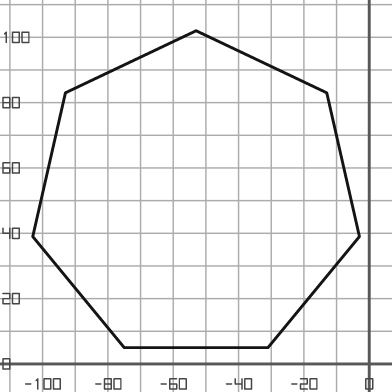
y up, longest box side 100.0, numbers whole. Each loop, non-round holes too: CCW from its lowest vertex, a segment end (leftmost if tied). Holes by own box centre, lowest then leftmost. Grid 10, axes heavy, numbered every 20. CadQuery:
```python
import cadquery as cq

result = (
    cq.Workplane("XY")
    .moveTo(-75.0, 5.0)
    .lineTo(-31.0, 5.0)
    .lineTo(-3.0, 39.0)
    .lineTo(-13.0, 83.0)
    .lineTo(-53.0, 102.0)
    .lineTo(-93.0, 83.0)
    .lineTo(-103.0, 39.0)
    .close()
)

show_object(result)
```